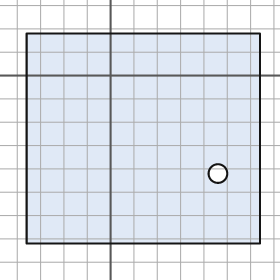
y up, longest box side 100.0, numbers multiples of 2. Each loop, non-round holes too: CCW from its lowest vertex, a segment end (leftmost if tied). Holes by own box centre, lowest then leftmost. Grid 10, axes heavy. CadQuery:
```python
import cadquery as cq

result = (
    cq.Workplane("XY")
    .moveTo(-36.0, -72.0)
    .lineTo(64.0, -72.0)
    .lineTo(64.0, 18.0)
    .lineTo(-36.0, 18.0)
    .close()
    .moveTo(46.0, -42.0)
    .circle(4.0)
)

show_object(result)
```